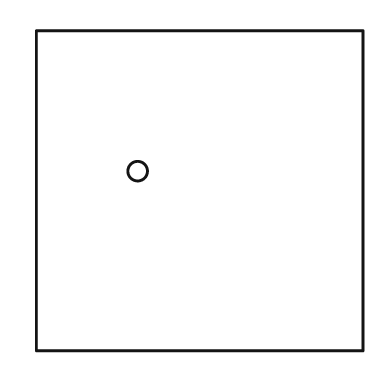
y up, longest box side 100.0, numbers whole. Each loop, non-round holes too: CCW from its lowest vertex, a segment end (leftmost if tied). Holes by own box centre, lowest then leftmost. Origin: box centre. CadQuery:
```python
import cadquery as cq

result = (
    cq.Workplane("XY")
    .moveTo(-50.0, -49.0)
    .lineTo(50.0, -49.0)
    .lineTo(50.0, 49.0)
    .lineTo(-50.0, 49.0)
    .close()
    .moveTo(-19.0, 6.0)
    .circle(3.0)
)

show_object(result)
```